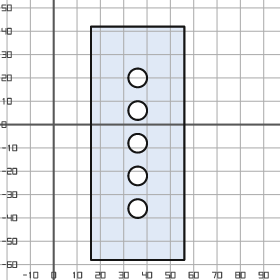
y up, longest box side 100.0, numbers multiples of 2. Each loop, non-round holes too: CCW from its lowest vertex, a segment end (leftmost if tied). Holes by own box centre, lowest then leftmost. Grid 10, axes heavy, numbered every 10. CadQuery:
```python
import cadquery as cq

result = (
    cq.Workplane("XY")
    .moveTo(16.0, -58.0)
    .lineTo(56.0, -58.0)
    .lineTo(56.0, 42.0)
    .lineTo(16.0, 42.0)
    .close()
    .moveTo(36.0, -36.0)
    .circle(4.0)
    .moveTo(36.0, -22.0)
    .circle(4.0)
    .moveTo(36.0, -8.0)
    .circle(4.0)
    .moveTo(36.0, 6.0)
    .circle(4.0)
    .moveTo(36.0, 20.0)
    .circle(4.0)
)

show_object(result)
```